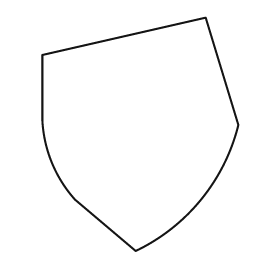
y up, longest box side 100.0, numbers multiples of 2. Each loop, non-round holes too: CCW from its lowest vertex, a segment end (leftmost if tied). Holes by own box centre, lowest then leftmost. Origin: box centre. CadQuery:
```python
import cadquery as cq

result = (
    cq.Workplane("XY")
    .moveTo(-2.0, -50.0)
    .threePointArc((26.0, -28.0), (42.0, 4.0))
    .lineTo(28.0, 50.0)
    .lineTo(-42.0, 34.0)
    .lineTo(-42.0, 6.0)
    .threePointArc((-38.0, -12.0), (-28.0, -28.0))
    .close()
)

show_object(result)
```